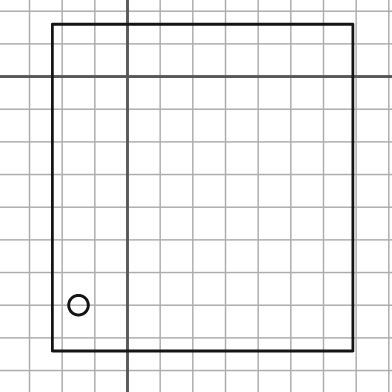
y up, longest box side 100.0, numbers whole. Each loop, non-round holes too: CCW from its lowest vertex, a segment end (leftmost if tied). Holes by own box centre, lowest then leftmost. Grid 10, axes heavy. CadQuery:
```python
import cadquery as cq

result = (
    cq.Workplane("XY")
    .moveTo(-23.0, -84.0)
    .lineTo(69.0, -84.0)
    .lineTo(69.0, 16.0)
    .lineTo(-23.0, 16.0)
    .close()
    .moveTo(-15.0, -70.0)
    .circle(3.0)
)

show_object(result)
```